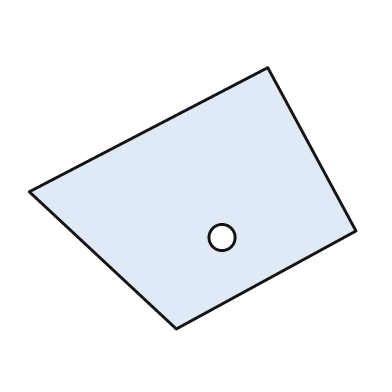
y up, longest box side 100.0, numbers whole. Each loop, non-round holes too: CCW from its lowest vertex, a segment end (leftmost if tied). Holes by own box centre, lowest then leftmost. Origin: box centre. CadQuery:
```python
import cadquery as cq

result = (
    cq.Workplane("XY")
    .moveTo(-5.0, -40.0)
    .lineTo(50.0, -10.0)
    .lineTo(23.0, 40.0)
    .lineTo(-50.0, 2.0)
    .close()
    .moveTo(9.0, -12.0)
    .circle(4.0)
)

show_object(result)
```